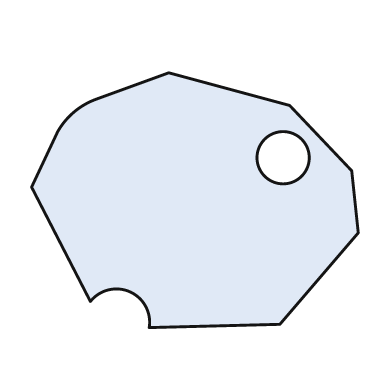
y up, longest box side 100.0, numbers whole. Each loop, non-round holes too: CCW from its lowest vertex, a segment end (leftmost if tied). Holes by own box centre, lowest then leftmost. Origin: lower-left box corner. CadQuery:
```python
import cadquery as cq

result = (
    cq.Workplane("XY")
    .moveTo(36.0, 0.0)
    .lineTo(76.0, 1.0)
    .lineTo(100.0, 29.0)
    .lineTo(98.0, 48.0)
    .lineTo(79.0, 68.0)
    .lineTo(42.0, 78.0)
    .lineTo(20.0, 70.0)
    .threePointArc((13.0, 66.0), (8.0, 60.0))
    .lineTo(0.0, 43.0)
    .lineTo(18.0, 8.0)
    .threePointArc((30.0, 11.0), (36.0, 0.0))
    .close()
    .moveTo(77.0, 52.0)
    .circle(8.0)
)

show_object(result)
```